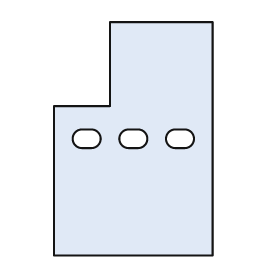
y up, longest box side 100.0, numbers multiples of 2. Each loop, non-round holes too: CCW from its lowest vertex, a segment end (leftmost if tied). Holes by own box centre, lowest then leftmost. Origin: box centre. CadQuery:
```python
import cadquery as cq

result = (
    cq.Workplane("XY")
    .moveTo(-34.0, -50.0)
    .lineTo(34.0, -50.0)
    .lineTo(34.0, 50.0)
    .lineTo(-10.0, 50.0)
    .lineTo(-10.0, 14.0)
    .lineTo(-34.0, 14.0)
    .close()
    .moveTo(-22.0, -4.0)
    .lineTo(-18.0, -4.0)
    .threePointArc((-14.0, 0.0), (-18.0, 4.0))
    .lineTo(-22.0, 4.0)
    .threePointArc((-26.0, 0.0), (-22.0, -4.0))
    .close()
    .moveTo(-2.0, -4.0)
    .lineTo(2.0, -4.0)
    .threePointArc((6.0, 0.0), (2.0, 4.0))
    .lineTo(-2.0, 4.0)
    .threePointArc((-6.0, 0.0), (-2.0, -4.0))
    .close()
    .moveTo(18.0, -4.0)
    .lineTo(22.0, -4.0)
    .threePointArc((26.0, 0.0), (22.0, 4.0))
    .lineTo(18.0, 4.0)
    .threePointArc((14.0, 0.0), (18.0, -4.0))
    .close()
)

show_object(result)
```